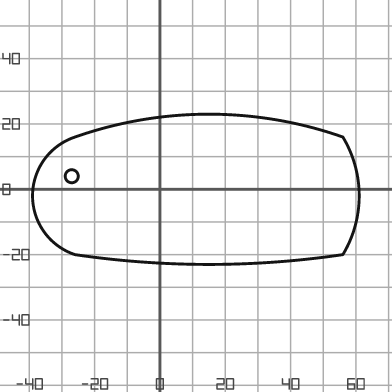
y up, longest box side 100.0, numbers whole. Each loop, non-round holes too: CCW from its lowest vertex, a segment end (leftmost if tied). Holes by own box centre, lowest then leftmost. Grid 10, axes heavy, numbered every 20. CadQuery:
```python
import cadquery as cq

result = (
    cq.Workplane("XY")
    .moveTo(-26.0, -20.0)
    .threePointArc((15.0, -23.0), (56.0, -20.0))
    .threePointArc((61.0, -2.0), (56.0, 16.0))
    .threePointArc((15.0, 23.0), (-26.0, 16.0))
    .threePointArc((-39.0, -2.0), (-26.0, -20.0))
    .close()
    .moveTo(-27.0, 4.0)
    .circle(2.0)
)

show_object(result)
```